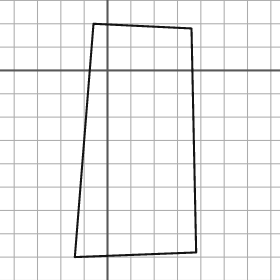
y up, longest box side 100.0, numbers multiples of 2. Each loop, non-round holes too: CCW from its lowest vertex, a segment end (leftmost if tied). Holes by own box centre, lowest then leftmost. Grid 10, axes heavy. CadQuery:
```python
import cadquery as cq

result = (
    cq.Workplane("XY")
    .moveTo(-14.0, -80.0)
    .lineTo(38.0, -78.0)
    .lineTo(36.0, 18.0)
    .lineTo(-6.0, 20.0)
    .close()
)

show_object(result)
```